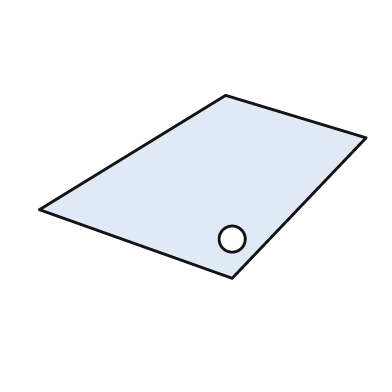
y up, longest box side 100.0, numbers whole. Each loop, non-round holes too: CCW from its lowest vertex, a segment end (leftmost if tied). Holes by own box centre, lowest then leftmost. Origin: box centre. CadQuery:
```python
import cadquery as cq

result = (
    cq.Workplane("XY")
    .moveTo(9.0, -28.0)
    .lineTo(50.0, 15.0)
    .lineTo(7.0, 28.0)
    .lineTo(-50.0, -7.0)
    .close()
    .moveTo(9.0, -16.0)
    .circle(4.0)
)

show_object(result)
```